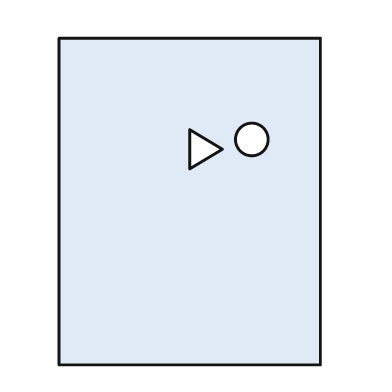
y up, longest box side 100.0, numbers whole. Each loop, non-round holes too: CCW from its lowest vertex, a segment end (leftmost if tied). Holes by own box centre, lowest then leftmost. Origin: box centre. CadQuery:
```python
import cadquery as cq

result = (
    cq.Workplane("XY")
    .moveTo(-40.0, -50.0)
    .lineTo(40.0, -50.0)
    .lineTo(40.0, 50.0)
    .lineTo(-40.0, 50.0)
    .close()
    .moveTo(0.0, 10.0)
    .lineTo(10.0, 16.0)
    .lineTo(0.0, 22.0)
    .close()
    .moveTo(19.0, 19.0)
    .circle(5.0)
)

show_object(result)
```